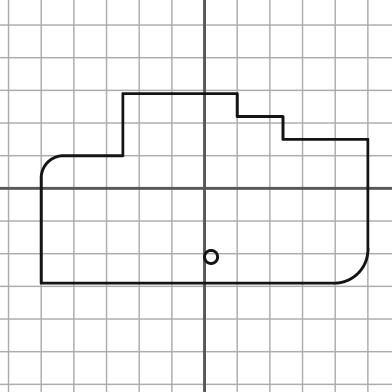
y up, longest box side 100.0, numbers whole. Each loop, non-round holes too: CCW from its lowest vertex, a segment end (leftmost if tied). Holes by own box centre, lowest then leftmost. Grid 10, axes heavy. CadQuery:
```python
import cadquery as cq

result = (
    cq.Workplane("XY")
    .moveTo(-50.0, -29.0)
    .lineTo(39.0, -29.0)
    .threePointArc((47.0, -26.0), (50.0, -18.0))
    .lineTo(50.0, 15.0)
    .lineTo(24.0, 15.0)
    .lineTo(24.0, 22.0)
    .lineTo(10.0, 22.0)
    .lineTo(10.0, 29.0)
    .lineTo(-25.0, 29.0)
    .lineTo(-25.0, 10.0)
    .lineTo(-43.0, 10.0)
    .threePointArc((-48.0, 8.0), (-50.0, 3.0))
    .close()
    .moveTo(2.0, -21.0)
    .circle(2.0)
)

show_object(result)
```